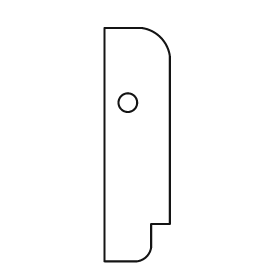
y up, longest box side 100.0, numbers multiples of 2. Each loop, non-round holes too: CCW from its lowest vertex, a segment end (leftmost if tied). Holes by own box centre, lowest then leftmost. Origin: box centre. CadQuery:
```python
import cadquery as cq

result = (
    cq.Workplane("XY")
    .moveTo(-14.0, -50.0)
    .lineTo(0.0, -50.0)
    .threePointArc((4.0, -48.0), (6.0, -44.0))
    .lineTo(6.0, -34.0)
    .lineTo(14.0, -34.0)
    .lineTo(14.0, 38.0)
    .threePointArc((10.0, 46.0), (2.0, 50.0))
    .lineTo(-14.0, 50.0)
    .close()
    .moveTo(-4.0, 18.0)
    .circle(4.0)
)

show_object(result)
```